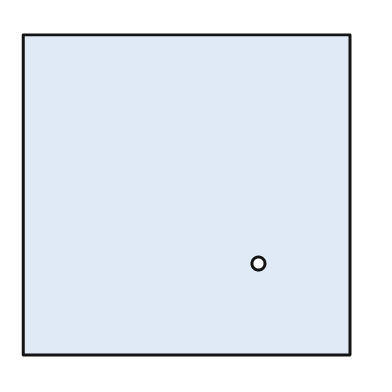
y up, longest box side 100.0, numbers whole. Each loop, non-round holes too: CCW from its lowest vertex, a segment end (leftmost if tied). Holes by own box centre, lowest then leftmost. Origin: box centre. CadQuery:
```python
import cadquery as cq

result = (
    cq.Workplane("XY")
    .moveTo(-50.0, -49.0)
    .lineTo(50.0, -49.0)
    .lineTo(50.0, 49.0)
    .lineTo(-50.0, 49.0)
    .close()
    .moveTo(22.0, -21.0)
    .circle(2.0)
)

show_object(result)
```